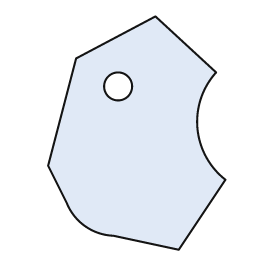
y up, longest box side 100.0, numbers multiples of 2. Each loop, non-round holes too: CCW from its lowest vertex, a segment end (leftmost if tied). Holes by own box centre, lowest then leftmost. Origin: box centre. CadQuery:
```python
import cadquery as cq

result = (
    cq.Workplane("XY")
    .moveTo(18.0, -50.0)
    .lineTo(38.0, -20.0)
    .threePointArc((26.0, 2.0), (34.0, 26.0))
    .lineTo(8.0, 50.0)
    .lineTo(-26.0, 32.0)
    .lineTo(-38.0, -14.0)
    .lineTo(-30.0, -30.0)
    .threePointArc((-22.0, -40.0), (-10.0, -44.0))
    .close()
    .moveTo(-8.0, 20.0)
    .circle(6.0)
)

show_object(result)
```